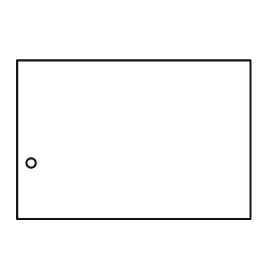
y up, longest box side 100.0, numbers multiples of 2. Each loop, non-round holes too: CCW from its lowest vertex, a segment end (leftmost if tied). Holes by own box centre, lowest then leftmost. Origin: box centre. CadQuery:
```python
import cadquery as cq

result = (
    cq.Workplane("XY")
    .moveTo(-50.0, -34.0)
    .lineTo(50.0, -34.0)
    .lineTo(50.0, 34.0)
    .lineTo(-50.0, 34.0)
    .close()
    .moveTo(-44.0, -10.0)
    .circle(2.0)
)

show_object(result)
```